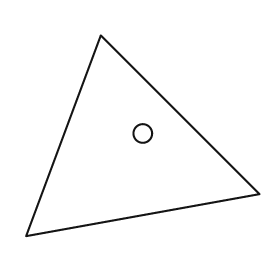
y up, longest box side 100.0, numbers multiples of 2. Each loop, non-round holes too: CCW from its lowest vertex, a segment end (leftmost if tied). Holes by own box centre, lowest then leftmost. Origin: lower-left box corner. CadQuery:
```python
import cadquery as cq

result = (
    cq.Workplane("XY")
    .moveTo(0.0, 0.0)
    .lineTo(100.0, 18.0)
    .lineTo(32.0, 86.0)
    .close()
    .moveTo(50.0, 44.0)
    .circle(4.0)
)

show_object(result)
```